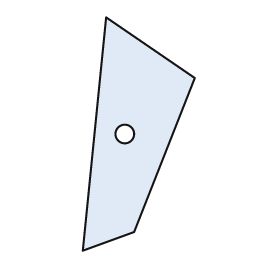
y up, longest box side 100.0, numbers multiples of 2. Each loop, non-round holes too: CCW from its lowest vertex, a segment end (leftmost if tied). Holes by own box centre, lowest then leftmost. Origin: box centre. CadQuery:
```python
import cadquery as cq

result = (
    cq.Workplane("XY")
    .moveTo(-24.0, -50.0)
    .lineTo(-2.0, -42.0)
    .lineTo(24.0, 24.0)
    .lineTo(-14.0, 50.0)
    .close()
    .moveTo(-6.0, 0.0)
    .circle(4.0)
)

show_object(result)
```